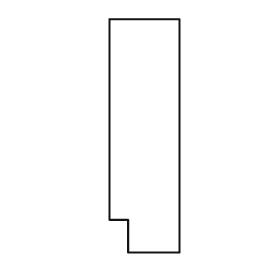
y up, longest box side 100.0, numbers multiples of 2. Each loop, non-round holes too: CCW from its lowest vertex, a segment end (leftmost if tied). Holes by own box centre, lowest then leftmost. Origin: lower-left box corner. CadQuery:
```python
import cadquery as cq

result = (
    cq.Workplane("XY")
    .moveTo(8.0, 0.0)
    .lineTo(30.0, 0.0)
    .lineTo(30.0, 100.0)
    .lineTo(0.0, 100.0)
    .lineTo(0.0, 14.0)
    .lineTo(8.0, 14.0)
    .close()
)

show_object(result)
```